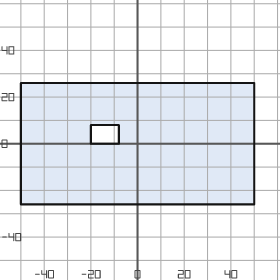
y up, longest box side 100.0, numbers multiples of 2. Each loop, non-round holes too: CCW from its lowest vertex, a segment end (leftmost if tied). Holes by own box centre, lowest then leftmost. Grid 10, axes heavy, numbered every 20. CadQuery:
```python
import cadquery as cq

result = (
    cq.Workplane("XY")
    .moveTo(-50.0, -26.0)
    .lineTo(50.0, -26.0)
    .lineTo(50.0, 26.0)
    .lineTo(-50.0, 26.0)
    .close()
    .moveTo(-20.0, 0.0)
    .lineTo(-8.0, 0.0)
    .lineTo(-8.0, 8.0)
    .lineTo(-20.0, 8.0)
    .close()
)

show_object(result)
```